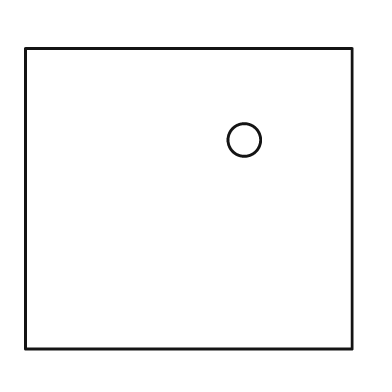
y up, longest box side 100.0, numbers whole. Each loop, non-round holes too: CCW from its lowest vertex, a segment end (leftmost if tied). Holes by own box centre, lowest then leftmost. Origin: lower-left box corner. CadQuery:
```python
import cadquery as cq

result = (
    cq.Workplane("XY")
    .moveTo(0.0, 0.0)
    .lineTo(100.0, 0.0)
    .lineTo(100.0, 92.0)
    .lineTo(0.0, 92.0)
    .close()
    .moveTo(67.0, 64.0)
    .circle(5.0)
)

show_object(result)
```